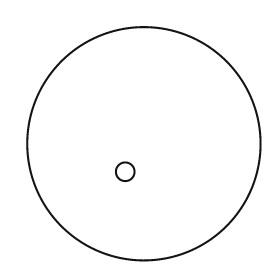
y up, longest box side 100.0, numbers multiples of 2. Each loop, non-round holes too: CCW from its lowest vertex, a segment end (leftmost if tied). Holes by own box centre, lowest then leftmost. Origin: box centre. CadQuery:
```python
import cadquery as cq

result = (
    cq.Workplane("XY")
    .moveTo(0.0, 0.0)
    .circle(50.0)
    .moveTo(-8.0, -12.0)
    .circle(4.0)
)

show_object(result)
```